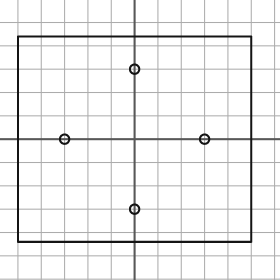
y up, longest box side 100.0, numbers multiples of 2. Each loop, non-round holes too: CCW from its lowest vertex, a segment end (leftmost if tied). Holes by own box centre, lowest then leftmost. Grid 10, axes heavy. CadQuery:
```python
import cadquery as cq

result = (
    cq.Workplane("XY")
    .moveTo(-50.0, -44.0)
    .lineTo(50.0, -44.0)
    .lineTo(50.0, 44.0)
    .lineTo(-50.0, 44.0)
    .close()
    .moveTo(0.0, -30.0)
    .circle(2.0)
    .moveTo(-30.0, 0.0)
    .circle(2.0)
    .moveTo(30.0, 0.0)
    .circle(2.0)
    .moveTo(0.0, 30.0)
    .circle(2.0)
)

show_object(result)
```